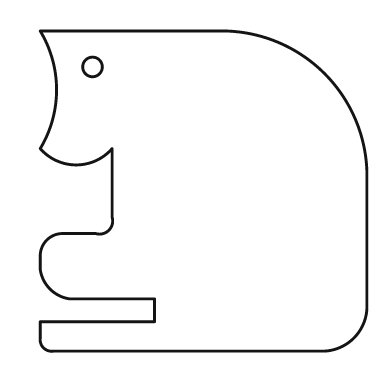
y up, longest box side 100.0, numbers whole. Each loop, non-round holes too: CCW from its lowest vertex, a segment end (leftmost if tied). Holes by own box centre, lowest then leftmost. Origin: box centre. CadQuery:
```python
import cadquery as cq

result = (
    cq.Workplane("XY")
    .moveTo(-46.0, -49.0)
    .lineTo(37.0, -49.0)
    .threePointArc((46.0, -45.0), (50.0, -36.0))
    .lineTo(50.0, 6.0)
    .threePointArc((37.0, 36.0), (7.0, 49.0))
    .lineTo(-50.0, 49.0)
    .threePointArc((-45.0, 31.0), (-50.0, 13.0))
    .threePointArc((-39.0, 8.0), (-28.0, 13.0))
    .lineTo(-28.0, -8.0)
    .threePointArc((-29.0, -12.0), (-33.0, -13.0))
    .lineTo(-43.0, -13.0)
    .threePointArc((-48.0, -15.0), (-50.0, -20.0))
    .lineTo(-50.0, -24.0)
    .threePointArc((-47.0, -30.0), (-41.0, -33.0))
    .lineTo(-15.0, -33.0)
    .lineTo(-15.0, -40.0)
    .lineTo(-50.0, -40.0)
    .lineTo(-50.0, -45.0)
    .threePointArc((-49.0, -48.0), (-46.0, -49.0))
    .close()
    .moveTo(-34.0, 38.0)
    .circle(3.0)
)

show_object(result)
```